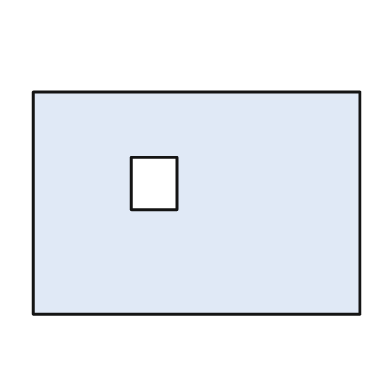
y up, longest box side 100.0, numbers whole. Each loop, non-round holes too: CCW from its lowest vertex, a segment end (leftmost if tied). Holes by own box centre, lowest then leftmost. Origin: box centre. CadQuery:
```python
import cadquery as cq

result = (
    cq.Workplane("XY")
    .moveTo(-50.0, -34.0)
    .lineTo(50.0, -34.0)
    .lineTo(50.0, 34.0)
    .lineTo(-50.0, 34.0)
    .close()
    .moveTo(-20.0, -2.0)
    .lineTo(-6.0, -2.0)
    .lineTo(-6.0, 14.0)
    .lineTo(-20.0, 14.0)
    .close()
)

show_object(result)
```